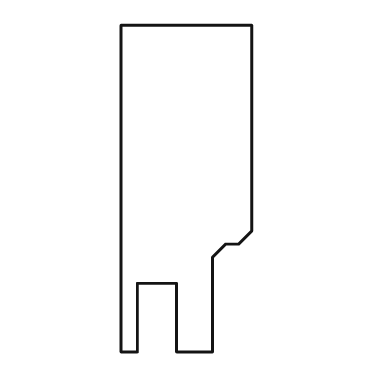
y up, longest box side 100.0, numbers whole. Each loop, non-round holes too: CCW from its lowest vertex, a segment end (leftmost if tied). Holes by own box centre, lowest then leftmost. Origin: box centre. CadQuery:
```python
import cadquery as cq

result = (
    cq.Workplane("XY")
    .moveTo(-20.0, -50.0)
    .lineTo(-15.0, -50.0)
    .lineTo(-15.0, -29.0)
    .lineTo(-3.0, -29.0)
    .lineTo(-3.0, -50.0)
    .lineTo(8.0, -50.0)
    .lineTo(8.0, -21.0)
    .lineTo(12.0, -17.0)
    .lineTo(16.0, -17.0)
    .lineTo(20.0, -13.0)
    .lineTo(20.0, 50.0)
    .lineTo(-20.0, 50.0)
    .close()
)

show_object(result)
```